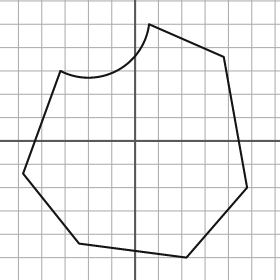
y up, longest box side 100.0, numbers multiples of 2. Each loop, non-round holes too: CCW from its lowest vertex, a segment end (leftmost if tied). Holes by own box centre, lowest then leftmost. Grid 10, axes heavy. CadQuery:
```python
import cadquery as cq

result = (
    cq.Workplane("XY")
    .moveTo(22.0, -50.0)
    .lineTo(48.0, -20.0)
    .lineTo(38.0, 36.0)
    .lineTo(6.0, 50.0)
    .threePointArc((-8.0, 30.0), (-32.0, 30.0))
    .lineTo(-48.0, -14.0)
    .lineTo(-24.0, -44.0)
    .close()
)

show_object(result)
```